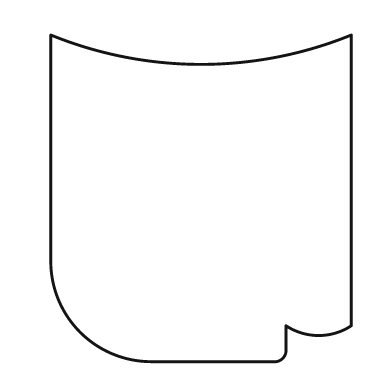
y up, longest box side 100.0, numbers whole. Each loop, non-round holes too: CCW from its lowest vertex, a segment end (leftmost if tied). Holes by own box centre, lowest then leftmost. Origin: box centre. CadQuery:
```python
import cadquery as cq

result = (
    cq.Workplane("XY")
    .moveTo(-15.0, -50.0)
    .lineTo(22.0, -50.0)
    .threePointArc((25.0, -49.0), (26.0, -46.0))
    .lineTo(26.0, -39.0)
    .threePointArc((36.0, -42.0), (46.0, -39.0))
    .lineTo(46.0, 50.0)
    .threePointArc((0.0, 41.0), (-46.0, 50.0))
    .lineTo(-46.0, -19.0)
    .threePointArc((-37.0, -41.0), (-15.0, -50.0))
    .close()
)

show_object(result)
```